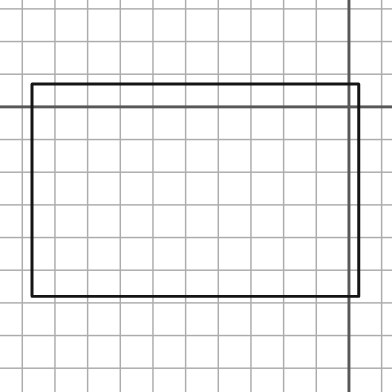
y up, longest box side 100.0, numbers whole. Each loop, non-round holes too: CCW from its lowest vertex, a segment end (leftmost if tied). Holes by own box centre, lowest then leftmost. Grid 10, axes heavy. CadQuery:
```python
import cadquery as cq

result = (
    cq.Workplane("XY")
    .moveTo(-97.0, -58.0)
    .lineTo(3.0, -58.0)
    .lineTo(3.0, 7.0)
    .lineTo(-97.0, 7.0)
    .close()
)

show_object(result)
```